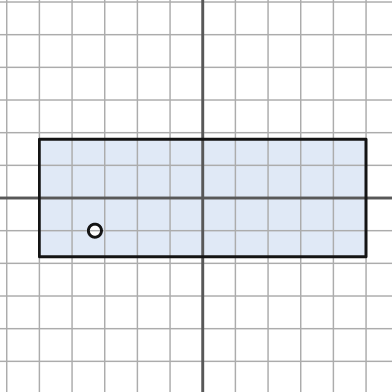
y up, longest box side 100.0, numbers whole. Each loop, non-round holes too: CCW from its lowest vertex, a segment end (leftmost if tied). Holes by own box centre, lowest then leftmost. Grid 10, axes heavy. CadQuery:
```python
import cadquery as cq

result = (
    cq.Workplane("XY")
    .moveTo(-50.0, -18.0)
    .lineTo(50.0, -18.0)
    .lineTo(50.0, 18.0)
    .lineTo(-50.0, 18.0)
    .close()
    .moveTo(-33.0, -10.0)
    .circle(2.0)
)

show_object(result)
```